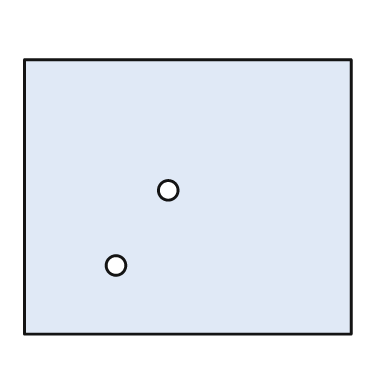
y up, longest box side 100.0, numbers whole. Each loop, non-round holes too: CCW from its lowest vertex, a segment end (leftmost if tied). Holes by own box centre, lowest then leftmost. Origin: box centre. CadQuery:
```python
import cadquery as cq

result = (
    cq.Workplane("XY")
    .moveTo(-50.0, -42.0)
    .lineTo(50.0, -42.0)
    .lineTo(50.0, 42.0)
    .lineTo(-50.0, 42.0)
    .close()
    .moveTo(-22.0, -21.0)
    .circle(3.0)
    .moveTo(-6.0, 2.0)
    .circle(3.0)
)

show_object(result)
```